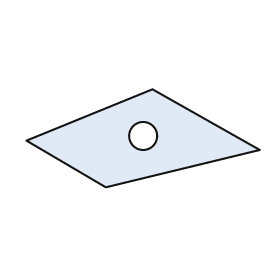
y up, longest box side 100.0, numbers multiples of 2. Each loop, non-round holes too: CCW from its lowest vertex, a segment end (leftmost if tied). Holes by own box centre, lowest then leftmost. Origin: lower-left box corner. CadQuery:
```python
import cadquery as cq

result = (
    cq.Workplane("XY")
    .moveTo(34.0, 0.0)
    .lineTo(100.0, 16.0)
    .lineTo(54.0, 42.0)
    .lineTo(0.0, 20.0)
    .close()
    .moveTo(50.0, 22.0)
    .circle(6.0)
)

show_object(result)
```